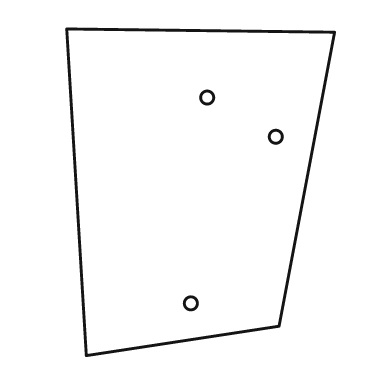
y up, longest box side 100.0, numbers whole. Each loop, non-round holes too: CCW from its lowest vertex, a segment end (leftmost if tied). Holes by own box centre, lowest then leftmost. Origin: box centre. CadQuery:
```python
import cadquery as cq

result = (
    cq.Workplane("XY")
    .moveTo(-35.0, -50.0)
    .lineTo(24.0, -41.0)
    .lineTo(41.0, 49.0)
    .lineTo(-41.0, 50.0)
    .close()
    .moveTo(-3.0, -34.0)
    .circle(2.0)
    .moveTo(23.0, 17.0)
    .circle(2.0)
    .moveTo(2.0, 29.0)
    .circle(2.0)
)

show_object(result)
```